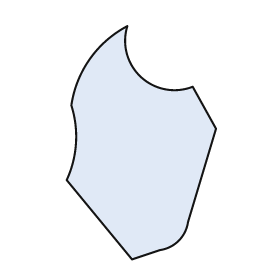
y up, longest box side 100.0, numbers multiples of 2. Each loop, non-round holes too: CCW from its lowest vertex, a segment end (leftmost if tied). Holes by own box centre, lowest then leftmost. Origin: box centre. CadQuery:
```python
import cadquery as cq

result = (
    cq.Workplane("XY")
    .moveTo(-4.0, -50.0)
    .lineTo(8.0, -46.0)
    .threePointArc((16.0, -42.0), (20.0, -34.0))
    .lineTo(32.0, 6.0)
    .lineTo(22.0, 24.0)
    .threePointArc((0.0, 28.0), (-6.0, 50.0))
    .threePointArc((-22.0, 36.0), (-30.0, 16.0))
    .threePointArc((-28.0, 0.0), (-32.0, -16.0))
    .close()
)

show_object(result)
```